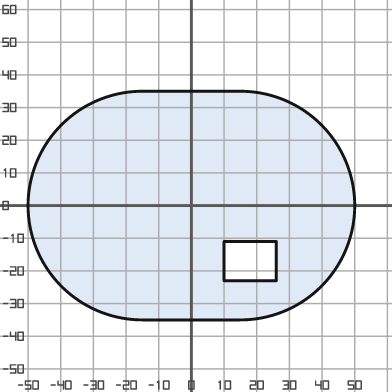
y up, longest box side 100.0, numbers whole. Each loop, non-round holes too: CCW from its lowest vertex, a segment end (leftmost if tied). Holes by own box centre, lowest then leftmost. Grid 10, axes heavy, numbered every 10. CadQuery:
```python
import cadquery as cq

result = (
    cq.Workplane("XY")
    .moveTo(-15.0, -35.0)
    .lineTo(15.0, -35.0)
    .threePointArc((50.0, 0.0), (15.0, 35.0))
    .lineTo(-15.0, 35.0)
    .threePointArc((-50.0, 0.0), (-15.0, -35.0))
    .close()
    .moveTo(10.0, -23.0)
    .lineTo(26.0, -23.0)
    .lineTo(26.0, -11.0)
    .lineTo(10.0, -11.0)
    .close()
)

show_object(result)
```